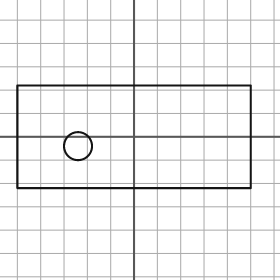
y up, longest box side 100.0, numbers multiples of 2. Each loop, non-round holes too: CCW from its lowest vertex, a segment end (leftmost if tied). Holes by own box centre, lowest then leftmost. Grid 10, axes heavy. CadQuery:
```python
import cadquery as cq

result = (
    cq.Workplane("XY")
    .moveTo(-50.0, -22.0)
    .lineTo(50.0, -22.0)
    .lineTo(50.0, 22.0)
    .lineTo(-50.0, 22.0)
    .close()
    .moveTo(-24.0, -4.0)
    .circle(6.0)
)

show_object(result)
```